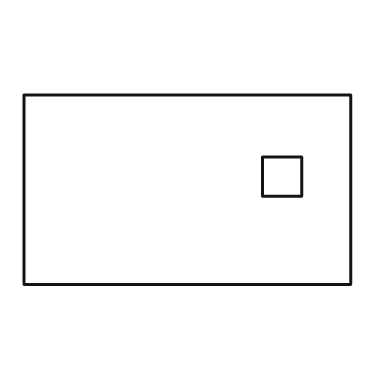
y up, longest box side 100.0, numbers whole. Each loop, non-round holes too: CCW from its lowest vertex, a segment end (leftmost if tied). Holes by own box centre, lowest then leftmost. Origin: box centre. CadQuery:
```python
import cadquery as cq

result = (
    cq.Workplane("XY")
    .moveTo(-50.0, -29.0)
    .lineTo(50.0, -29.0)
    .lineTo(50.0, 29.0)
    .lineTo(-50.0, 29.0)
    .close()
    .moveTo(23.0, -2.0)
    .lineTo(35.0, -2.0)
    .lineTo(35.0, 10.0)
    .lineTo(23.0, 10.0)
    .close()
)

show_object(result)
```